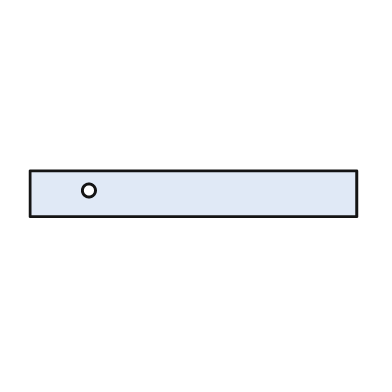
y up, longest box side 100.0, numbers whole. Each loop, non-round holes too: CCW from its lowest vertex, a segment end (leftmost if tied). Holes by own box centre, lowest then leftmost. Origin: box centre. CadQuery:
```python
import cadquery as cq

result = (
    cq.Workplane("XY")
    .moveTo(-50.0, -7.0)
    .lineTo(50.0, -7.0)
    .lineTo(50.0, 7.0)
    .lineTo(-50.0, 7.0)
    .close()
    .moveTo(-32.0, 1.0)
    .circle(2.0)
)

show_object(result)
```